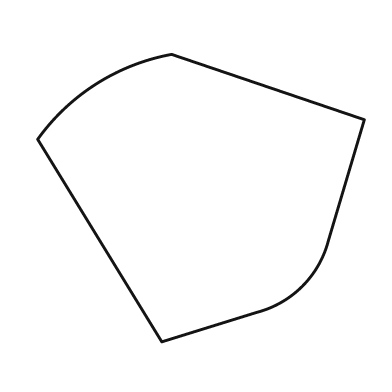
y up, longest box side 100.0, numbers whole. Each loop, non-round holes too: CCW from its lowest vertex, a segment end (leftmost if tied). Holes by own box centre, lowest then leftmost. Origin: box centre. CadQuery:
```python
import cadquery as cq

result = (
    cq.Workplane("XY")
    .moveTo(-12.0, -44.0)
    .lineTo(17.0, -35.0)
    .threePointArc((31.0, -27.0), (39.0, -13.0))
    .lineTo(50.0, 24.0)
    .lineTo(-9.0, 44.0)
    .threePointArc((-32.0, 35.0), (-50.0, 18.0))
    .close()
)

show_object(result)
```